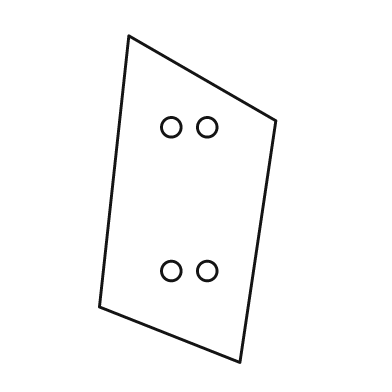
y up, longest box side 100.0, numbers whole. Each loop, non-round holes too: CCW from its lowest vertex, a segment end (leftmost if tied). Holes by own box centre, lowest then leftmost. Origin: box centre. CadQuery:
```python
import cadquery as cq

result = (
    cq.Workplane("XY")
    .moveTo(16.0, -50.0)
    .lineTo(27.0, 24.0)
    .lineTo(-18.0, 50.0)
    .lineTo(-27.0, -33.0)
    .close()
    .moveTo(-5.0, -22.0)
    .circle(3.0)
    .moveTo(6.0, -22.0)
    .circle(3.0)
    .moveTo(-5.0, 22.0)
    .circle(3.0)
    .moveTo(6.0, 22.0)
    .circle(3.0)
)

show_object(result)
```